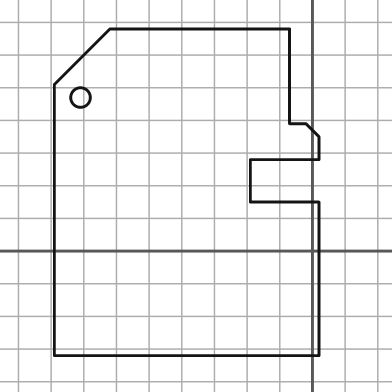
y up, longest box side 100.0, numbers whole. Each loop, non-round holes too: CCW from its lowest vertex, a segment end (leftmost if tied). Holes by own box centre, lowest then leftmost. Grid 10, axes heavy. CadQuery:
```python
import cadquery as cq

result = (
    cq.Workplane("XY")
    .moveTo(-79.0, -32.0)
    .lineTo(2.0, -32.0)
    .lineTo(2.0, 15.0)
    .lineTo(-19.0, 15.0)
    .lineTo(-19.0, 28.0)
    .lineTo(2.0, 28.0)
    .lineTo(2.0, 35.0)
    .lineTo(-2.0, 39.0)
    .lineTo(-7.0, 39.0)
    .lineTo(-7.0, 68.0)
    .lineTo(-62.0, 68.0)
    .lineTo(-79.0, 51.0)
    .close()
    .moveTo(-71.0, 47.0)
    .circle(3.0)
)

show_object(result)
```